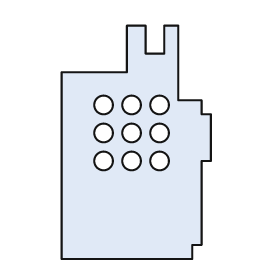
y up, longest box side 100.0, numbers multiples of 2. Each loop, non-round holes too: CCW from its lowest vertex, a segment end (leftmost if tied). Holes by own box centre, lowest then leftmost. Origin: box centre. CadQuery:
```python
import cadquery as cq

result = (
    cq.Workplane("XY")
    .moveTo(-32.0, -50.0)
    .lineTo(24.0, -50.0)
    .lineTo(24.0, -44.0)
    .lineTo(28.0, -44.0)
    .lineTo(28.0, -8.0)
    .lineTo(32.0, -8.0)
    .lineTo(32.0, 12.0)
    .lineTo(28.0, 12.0)
    .lineTo(28.0, 18.0)
    .lineTo(18.0, 18.0)
    .lineTo(18.0, 50.0)
    .lineTo(12.0, 50.0)
    .lineTo(12.0, 38.0)
    .lineTo(4.0, 38.0)
    .lineTo(4.0, 50.0)
    .lineTo(-4.0, 50.0)
    .lineTo(-4.0, 30.0)
    .lineTo(-32.0, 30.0)
    .close()
    .moveTo(-14.0, -8.0)
    .circle(4.0)
    .moveTo(-2.0, -8.0)
    .circle(4.0)
    .moveTo(10.0, -8.0)
    .circle(4.0)
    .moveTo(-14.0, 4.0)
    .circle(4.0)
    .moveTo(-2.0, 4.0)
    .circle(4.0)
    .moveTo(10.0, 4.0)
    .circle(4.0)
    .moveTo(-14.0, 16.0)
    .circle(4.0)
    .moveTo(-2.0, 16.0)
    .circle(4.0)
    .moveTo(10.0, 16.0)
    .circle(4.0)
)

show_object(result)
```